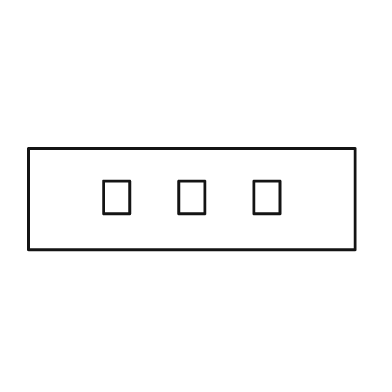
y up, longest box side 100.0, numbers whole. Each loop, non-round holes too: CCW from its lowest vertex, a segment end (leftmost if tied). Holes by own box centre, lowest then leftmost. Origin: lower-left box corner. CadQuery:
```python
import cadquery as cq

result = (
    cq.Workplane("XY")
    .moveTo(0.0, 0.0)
    .lineTo(100.0, 0.0)
    .lineTo(100.0, 31.0)
    .lineTo(0.0, 31.0)
    .close()
    .moveTo(23.0, 11.0)
    .lineTo(31.0, 11.0)
    .lineTo(31.0, 21.0)
    .lineTo(23.0, 21.0)
    .close()
    .moveTo(46.0, 11.0)
    .lineTo(54.0, 11.0)
    .lineTo(54.0, 21.0)
    .lineTo(46.0, 21.0)
    .close()
    .moveTo(69.0, 11.0)
    .lineTo(77.0, 11.0)
    .lineTo(77.0, 21.0)
    .lineTo(69.0, 21.0)
    .close()
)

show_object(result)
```